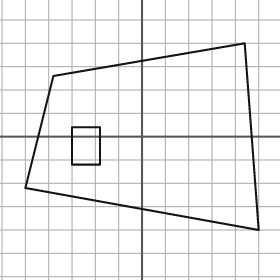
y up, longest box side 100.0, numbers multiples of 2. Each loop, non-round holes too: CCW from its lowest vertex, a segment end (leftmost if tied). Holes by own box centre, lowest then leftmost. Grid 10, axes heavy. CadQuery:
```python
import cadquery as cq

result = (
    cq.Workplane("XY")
    .moveTo(50.0, -40.0)
    .lineTo(44.0, 40.0)
    .lineTo(-38.0, 26.0)
    .lineTo(-50.0, -22.0)
    .close()
    .moveTo(-30.0, -12.0)
    .lineTo(-18.0, -12.0)
    .lineTo(-18.0, 4.0)
    .lineTo(-30.0, 4.0)
    .close()
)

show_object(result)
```